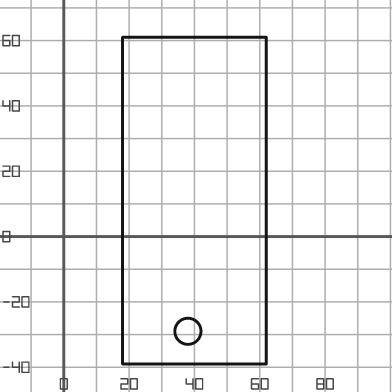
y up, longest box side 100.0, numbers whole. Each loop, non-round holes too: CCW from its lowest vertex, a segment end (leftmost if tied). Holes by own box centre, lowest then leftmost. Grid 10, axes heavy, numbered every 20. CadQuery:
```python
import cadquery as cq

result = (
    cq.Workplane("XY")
    .moveTo(18.0, -39.0)
    .lineTo(62.0, -39.0)
    .lineTo(62.0, 61.0)
    .lineTo(18.0, 61.0)
    .close()
    .moveTo(38.0, -29.0)
    .circle(4.0)
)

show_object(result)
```